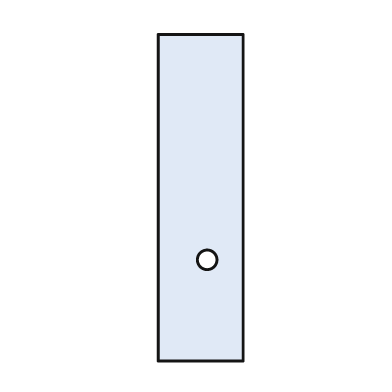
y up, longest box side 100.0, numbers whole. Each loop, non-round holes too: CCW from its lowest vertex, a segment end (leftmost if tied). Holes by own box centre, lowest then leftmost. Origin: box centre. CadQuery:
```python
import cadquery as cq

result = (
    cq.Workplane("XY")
    .moveTo(-13.0, -50.0)
    .lineTo(13.0, -50.0)
    .lineTo(13.0, 50.0)
    .lineTo(-13.0, 50.0)
    .close()
    .moveTo(2.0, -19.0)
    .circle(3.0)
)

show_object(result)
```